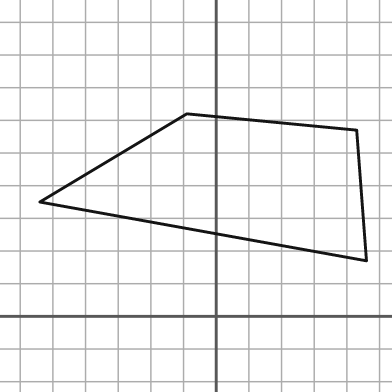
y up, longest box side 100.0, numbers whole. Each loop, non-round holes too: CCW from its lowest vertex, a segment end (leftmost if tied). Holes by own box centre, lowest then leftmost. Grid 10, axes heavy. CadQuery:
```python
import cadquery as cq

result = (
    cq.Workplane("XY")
    .moveTo(46.0, 17.0)
    .lineTo(43.0, 57.0)
    .lineTo(-9.0, 62.0)
    .lineTo(-54.0, 35.0)
    .close()
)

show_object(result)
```